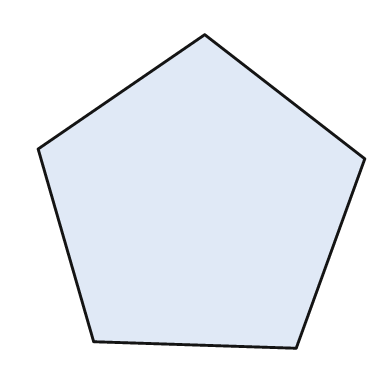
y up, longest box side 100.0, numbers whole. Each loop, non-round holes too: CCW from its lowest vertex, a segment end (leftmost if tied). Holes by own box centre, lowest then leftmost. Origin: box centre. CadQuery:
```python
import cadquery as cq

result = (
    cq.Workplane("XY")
    .moveTo(29.0, -48.0)
    .lineTo(50.0, 10.0)
    .lineTo(1.0, 48.0)
    .lineTo(-50.0, 13.0)
    .lineTo(-33.0, -46.0)
    .close()
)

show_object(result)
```